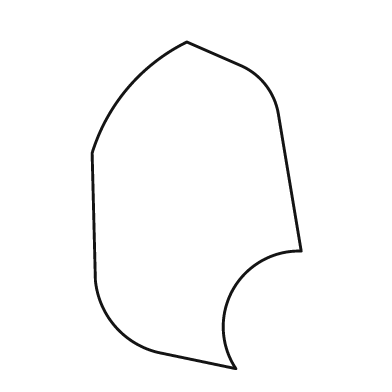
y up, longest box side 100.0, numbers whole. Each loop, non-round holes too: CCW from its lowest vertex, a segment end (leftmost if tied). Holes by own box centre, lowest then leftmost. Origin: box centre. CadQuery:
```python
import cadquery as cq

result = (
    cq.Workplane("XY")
    .moveTo(12.0, -50.0)
    .threePointArc((11.0, -26.0), (32.0, -14.0))
    .lineTo(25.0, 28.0)
    .threePointArc((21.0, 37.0), (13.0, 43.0))
    .lineTo(-3.0, 50.0)
    .threePointArc((-21.0, 36.0), (-32.0, 16.0))
    .lineTo(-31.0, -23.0)
    .threePointArc((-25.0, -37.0), (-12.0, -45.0))
    .close()
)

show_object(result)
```